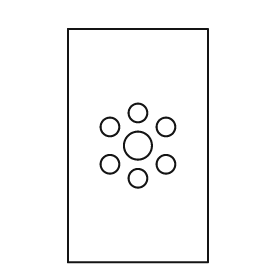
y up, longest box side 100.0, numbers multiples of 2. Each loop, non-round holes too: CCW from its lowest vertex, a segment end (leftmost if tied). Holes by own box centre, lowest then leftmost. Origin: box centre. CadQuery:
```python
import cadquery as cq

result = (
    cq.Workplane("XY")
    .moveTo(-30.0, -50.0)
    .lineTo(30.0, -50.0)
    .lineTo(30.0, 50.0)
    .lineTo(-30.0, 50.0)
    .close()
    .moveTo(0.0, -14.0)
    .circle(4.0)
    .moveTo(-12.0, -8.0)
    .circle(4.0)
    .moveTo(12.0, -8.0)
    .circle(4.0)
    .moveTo(0.0, 0.0)
    .circle(6.0)
    .moveTo(-12.0, 8.0)
    .circle(4.0)
    .moveTo(12.0, 8.0)
    .circle(4.0)
    .moveTo(0.0, 14.0)
    .circle(4.0)
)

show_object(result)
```